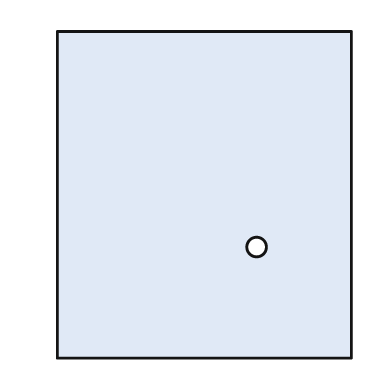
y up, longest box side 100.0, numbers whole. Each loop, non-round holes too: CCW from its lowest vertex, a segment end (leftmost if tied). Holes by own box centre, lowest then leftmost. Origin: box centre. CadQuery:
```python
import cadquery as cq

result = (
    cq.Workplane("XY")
    .moveTo(-45.0, -50.0)
    .lineTo(45.0, -50.0)
    .lineTo(45.0, 50.0)
    .lineTo(-45.0, 50.0)
    .close()
    .moveTo(16.0, -16.0)
    .circle(3.0)
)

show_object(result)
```